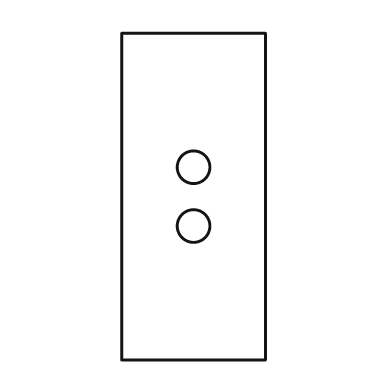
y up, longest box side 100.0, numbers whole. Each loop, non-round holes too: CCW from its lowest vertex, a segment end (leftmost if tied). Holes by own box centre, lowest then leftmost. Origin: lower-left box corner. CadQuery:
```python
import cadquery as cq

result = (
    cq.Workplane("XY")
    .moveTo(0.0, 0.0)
    .lineTo(44.0, 0.0)
    .lineTo(44.0, 100.0)
    .lineTo(0.0, 100.0)
    .close()
    .moveTo(22.0, 41.0)
    .circle(5.0)
    .moveTo(22.0, 59.0)
    .circle(5.0)
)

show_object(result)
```